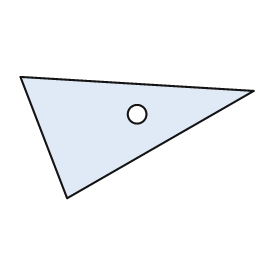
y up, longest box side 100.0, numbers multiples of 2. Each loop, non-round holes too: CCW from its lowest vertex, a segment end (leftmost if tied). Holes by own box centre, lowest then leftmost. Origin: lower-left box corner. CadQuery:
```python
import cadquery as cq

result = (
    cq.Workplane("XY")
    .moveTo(20.0, 0.0)
    .lineTo(100.0, 46.0)
    .lineTo(0.0, 52.0)
    .close()
    .moveTo(50.0, 36.0)
    .circle(4.0)
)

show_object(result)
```